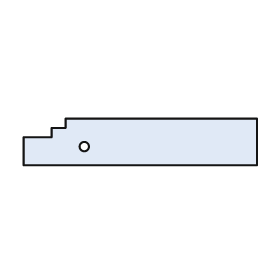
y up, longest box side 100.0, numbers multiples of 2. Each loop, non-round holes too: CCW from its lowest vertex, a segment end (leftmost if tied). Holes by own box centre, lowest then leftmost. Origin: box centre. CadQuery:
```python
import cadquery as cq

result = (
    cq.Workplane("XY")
    .moveTo(-50.0, -10.0)
    .lineTo(50.0, -10.0)
    .lineTo(50.0, 10.0)
    .lineTo(-32.0, 10.0)
    .lineTo(-32.0, 6.0)
    .lineTo(-38.0, 6.0)
    .lineTo(-38.0, 2.0)
    .lineTo(-50.0, 2.0)
    .close()
    .moveTo(-24.0, -2.0)
    .circle(2.0)
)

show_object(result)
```